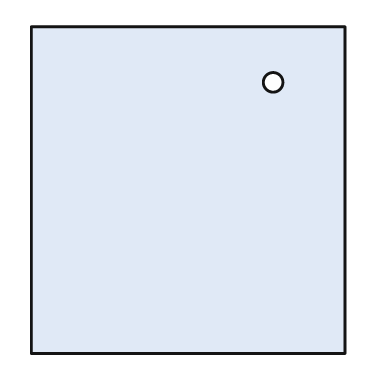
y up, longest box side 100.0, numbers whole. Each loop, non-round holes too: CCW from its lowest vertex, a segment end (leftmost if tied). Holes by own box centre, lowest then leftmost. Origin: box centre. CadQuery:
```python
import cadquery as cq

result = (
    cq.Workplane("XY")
    .moveTo(-48.0, -50.0)
    .lineTo(48.0, -50.0)
    .lineTo(48.0, 50.0)
    .lineTo(-48.0, 50.0)
    .close()
    .moveTo(26.0, 33.0)
    .circle(3.0)
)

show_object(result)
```